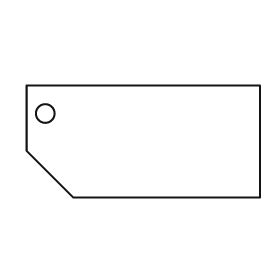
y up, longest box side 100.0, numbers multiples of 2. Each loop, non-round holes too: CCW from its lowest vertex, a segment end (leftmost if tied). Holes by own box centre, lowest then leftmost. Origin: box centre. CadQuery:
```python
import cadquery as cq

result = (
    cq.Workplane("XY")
    .moveTo(-30.0, -24.0)
    .lineTo(50.0, -24.0)
    .lineTo(50.0, 24.0)
    .lineTo(-50.0, 24.0)
    .lineTo(-50.0, -4.0)
    .close()
    .moveTo(-42.0, 12.0)
    .circle(4.0)
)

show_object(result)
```